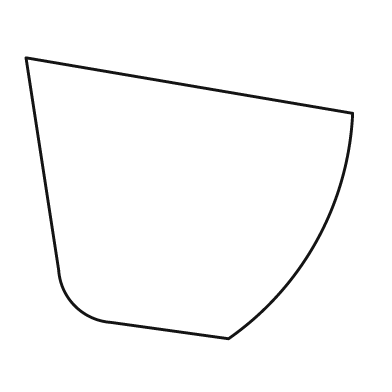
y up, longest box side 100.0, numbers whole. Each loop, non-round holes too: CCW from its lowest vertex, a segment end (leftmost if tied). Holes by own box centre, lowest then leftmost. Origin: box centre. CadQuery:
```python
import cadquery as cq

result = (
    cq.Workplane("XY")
    .moveTo(12.0, -43.0)
    .threePointArc((39.0, -13.0), (50.0, 26.0))
    .lineTo(-50.0, 43.0)
    .lineTo(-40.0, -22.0)
    .threePointArc((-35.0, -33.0), (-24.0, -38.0))
    .close()
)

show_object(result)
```